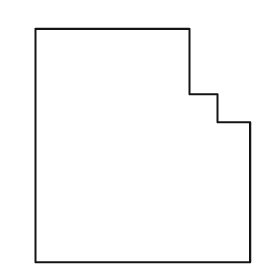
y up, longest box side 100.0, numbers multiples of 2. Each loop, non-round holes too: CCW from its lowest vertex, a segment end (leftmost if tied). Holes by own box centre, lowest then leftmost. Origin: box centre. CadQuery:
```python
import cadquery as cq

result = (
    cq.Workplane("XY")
    .moveTo(-46.0, -50.0)
    .lineTo(46.0, -50.0)
    .lineTo(46.0, 10.0)
    .lineTo(32.0, 10.0)
    .lineTo(32.0, 22.0)
    .lineTo(20.0, 22.0)
    .lineTo(20.0, 50.0)
    .lineTo(-46.0, 50.0)
    .close()
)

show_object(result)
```